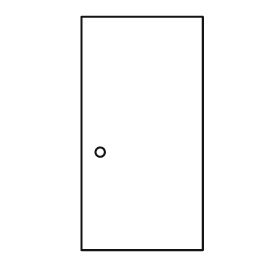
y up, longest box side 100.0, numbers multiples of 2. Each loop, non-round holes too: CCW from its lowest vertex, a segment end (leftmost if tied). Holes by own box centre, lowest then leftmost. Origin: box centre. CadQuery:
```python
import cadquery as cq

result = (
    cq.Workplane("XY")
    .moveTo(-26.0, -50.0)
    .lineTo(26.0, -50.0)
    .lineTo(26.0, 50.0)
    .lineTo(-26.0, 50.0)
    .close()
    .moveTo(-18.0, -8.0)
    .circle(2.0)
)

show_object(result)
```